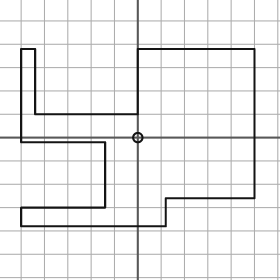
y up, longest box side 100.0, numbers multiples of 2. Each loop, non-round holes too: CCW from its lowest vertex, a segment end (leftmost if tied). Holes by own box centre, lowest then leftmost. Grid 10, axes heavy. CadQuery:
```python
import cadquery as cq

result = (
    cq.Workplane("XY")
    .moveTo(-50.0, -38.0)
    .lineTo(12.0, -38.0)
    .lineTo(12.0, -26.0)
    .lineTo(50.0, -26.0)
    .lineTo(50.0, 38.0)
    .lineTo(0.0, 38.0)
    .lineTo(0.0, 10.0)
    .lineTo(-44.0, 10.0)
    .lineTo(-44.0, 38.0)
    .lineTo(-50.0, 38.0)
    .lineTo(-50.0, -2.0)
    .lineTo(-14.0, -2.0)
    .lineTo(-14.0, -30.0)
    .lineTo(-50.0, -30.0)
    .close()
    .moveTo(0.0, 0.0)
    .circle(2.0)
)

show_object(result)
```